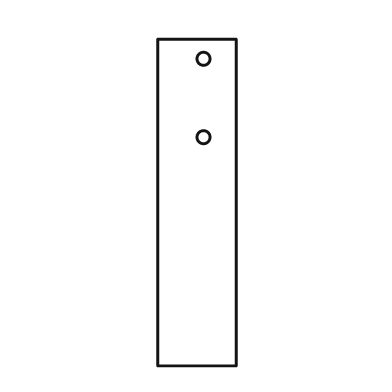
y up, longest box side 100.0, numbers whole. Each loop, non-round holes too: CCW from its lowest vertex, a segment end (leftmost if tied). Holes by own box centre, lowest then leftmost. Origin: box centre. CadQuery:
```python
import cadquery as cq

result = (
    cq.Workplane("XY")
    .moveTo(-12.0, -50.0)
    .lineTo(12.0, -50.0)
    .lineTo(12.0, 50.0)
    .lineTo(-12.0, 50.0)
    .close()
    .moveTo(2.0, 20.0)
    .circle(2.0)
    .moveTo(2.0, 44.0)
    .circle(2.0)
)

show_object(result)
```